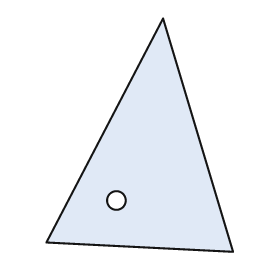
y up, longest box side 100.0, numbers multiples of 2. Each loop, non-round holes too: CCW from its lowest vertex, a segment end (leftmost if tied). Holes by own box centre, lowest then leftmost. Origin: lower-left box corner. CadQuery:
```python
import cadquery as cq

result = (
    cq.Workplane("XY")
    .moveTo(80.0, 0.0)
    .lineTo(50.0, 100.0)
    .lineTo(0.0, 4.0)
    .close()
    .moveTo(30.0, 22.0)
    .circle(4.0)
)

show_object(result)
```